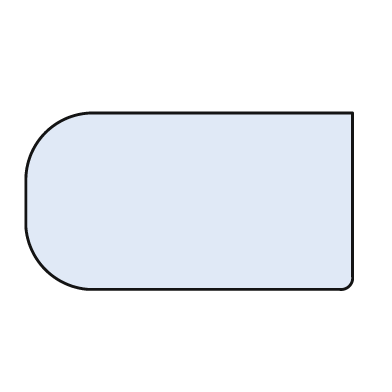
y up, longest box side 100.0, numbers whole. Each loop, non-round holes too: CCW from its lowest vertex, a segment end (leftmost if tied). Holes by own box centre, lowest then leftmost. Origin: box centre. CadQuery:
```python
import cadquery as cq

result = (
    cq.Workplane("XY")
    .moveTo(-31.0, -27.0)
    .lineTo(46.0, -27.0)
    .threePointArc((49.0, -26.0), (50.0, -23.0))
    .lineTo(50.0, 27.0)
    .lineTo(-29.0, 27.0)
    .threePointArc((-44.0, 21.0), (-50.0, 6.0))
    .lineTo(-50.0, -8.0)
    .threePointArc((-44.0, -21.0), (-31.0, -27.0))
    .close()
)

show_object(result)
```